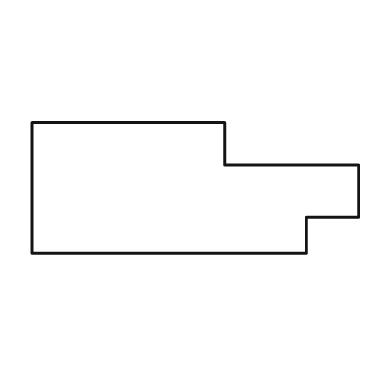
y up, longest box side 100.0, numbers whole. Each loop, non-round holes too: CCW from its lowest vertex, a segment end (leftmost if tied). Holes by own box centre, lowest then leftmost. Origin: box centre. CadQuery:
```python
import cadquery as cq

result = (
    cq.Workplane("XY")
    .moveTo(-50.0, -20.0)
    .lineTo(34.0, -20.0)
    .lineTo(34.0, -9.0)
    .lineTo(50.0, -9.0)
    .lineTo(50.0, 7.0)
    .lineTo(9.0, 7.0)
    .lineTo(9.0, 20.0)
    .lineTo(-50.0, 20.0)
    .close()
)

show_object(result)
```